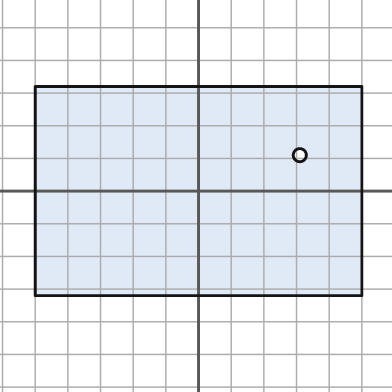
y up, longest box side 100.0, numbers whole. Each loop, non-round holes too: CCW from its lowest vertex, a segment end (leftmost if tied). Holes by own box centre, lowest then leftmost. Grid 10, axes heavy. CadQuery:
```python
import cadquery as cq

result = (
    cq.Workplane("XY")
    .moveTo(-50.0, -32.0)
    .lineTo(50.0, -32.0)
    .lineTo(50.0, 32.0)
    .lineTo(-50.0, 32.0)
    .close()
    .moveTo(31.0, 11.0)
    .circle(2.0)
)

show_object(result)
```